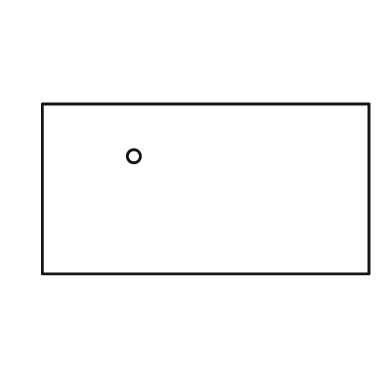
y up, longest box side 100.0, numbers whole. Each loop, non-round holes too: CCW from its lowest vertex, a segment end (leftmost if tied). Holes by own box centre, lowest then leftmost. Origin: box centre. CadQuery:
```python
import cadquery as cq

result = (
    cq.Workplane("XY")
    .moveTo(-50.0, -26.0)
    .lineTo(50.0, -26.0)
    .lineTo(50.0, 26.0)
    .lineTo(-50.0, 26.0)
    .close()
    .moveTo(-22.0, 10.0)
    .circle(2.0)
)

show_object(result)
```